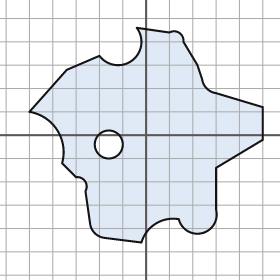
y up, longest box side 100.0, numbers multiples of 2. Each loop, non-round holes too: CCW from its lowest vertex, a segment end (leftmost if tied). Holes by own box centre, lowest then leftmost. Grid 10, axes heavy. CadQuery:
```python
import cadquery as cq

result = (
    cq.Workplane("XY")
    .moveTo(-2.0, -46.0)
    .threePointArc((4.0, -38.0), (14.0, -36.0))
    .threePointArc((24.0, -42.0), (30.0, -32.0))
    .lineTo(30.0, -14.0)
    .lineTo(50.0, -2.0)
    .lineTo(50.0, 12.0)
    .lineTo(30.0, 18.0)
    .threePointArc((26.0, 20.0), (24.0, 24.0))
    .lineTo(22.0, 30.0)
    .lineTo(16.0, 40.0)
    .threePointArc((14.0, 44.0), (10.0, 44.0))
    .lineTo(-4.0, 46.0)
    .threePointArc((-6.0, 32.0), (-20.0, 34.0))
    .lineTo(-34.0, 28.0)
    .lineTo(-50.0, 10.0)
    .threePointArc((-38.0, 2.0), (-36.0, -12.0))
    .lineTo(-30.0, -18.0)
    .threePointArc((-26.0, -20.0), (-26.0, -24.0))
    .lineTo(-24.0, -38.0)
    .threePointArc((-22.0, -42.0), (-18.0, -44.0))
    .close()
    .moveTo(-16.0, -4.0)
    .circle(6.0)
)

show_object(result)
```